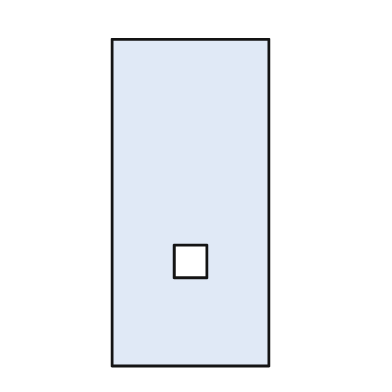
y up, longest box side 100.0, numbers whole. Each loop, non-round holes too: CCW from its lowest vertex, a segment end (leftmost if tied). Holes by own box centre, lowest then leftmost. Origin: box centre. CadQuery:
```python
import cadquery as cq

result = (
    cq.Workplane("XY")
    .moveTo(-24.0, -50.0)
    .lineTo(24.0, -50.0)
    .lineTo(24.0, 50.0)
    .lineTo(-24.0, 50.0)
    .close()
    .moveTo(-5.0, -23.0)
    .lineTo(5.0, -23.0)
    .lineTo(5.0, -13.0)
    .lineTo(-5.0, -13.0)
    .close()
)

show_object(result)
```